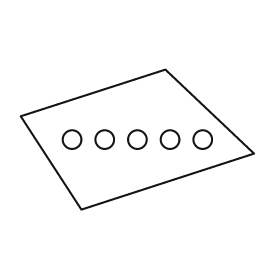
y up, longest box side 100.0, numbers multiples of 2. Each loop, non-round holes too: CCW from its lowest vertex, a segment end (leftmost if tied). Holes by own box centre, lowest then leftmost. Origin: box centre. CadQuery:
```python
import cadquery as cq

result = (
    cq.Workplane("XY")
    .moveTo(-24.0, -30.0)
    .lineTo(50.0, -6.0)
    .lineTo(12.0, 30.0)
    .lineTo(-50.0, 10.0)
    .close()
    .moveTo(-28.0, 0.0)
    .circle(4.0)
    .moveTo(-14.0, 0.0)
    .circle(4.0)
    .moveTo(0.0, 0.0)
    .circle(4.0)
    .moveTo(14.0, 0.0)
    .circle(4.0)
    .moveTo(28.0, 0.0)
    .circle(4.0)
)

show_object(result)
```